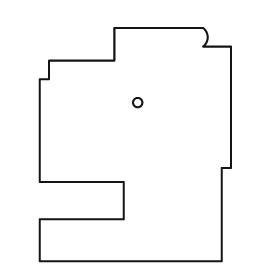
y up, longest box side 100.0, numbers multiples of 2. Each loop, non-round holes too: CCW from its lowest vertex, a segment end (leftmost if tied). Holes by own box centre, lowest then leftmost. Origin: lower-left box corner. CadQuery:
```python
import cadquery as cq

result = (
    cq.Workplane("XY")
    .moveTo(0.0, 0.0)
    .lineTo(78.0, 0.0)
    .lineTo(78.0, 40.0)
    .lineTo(82.0, 40.0)
    .lineTo(82.0, 92.0)
    .lineTo(70.0, 92.0)
    .threePointArc((72.0, 96.0), (70.0, 100.0))
    .lineTo(32.0, 100.0)
    .lineTo(32.0, 86.0)
    .lineTo(4.0, 86.0)
    .lineTo(4.0, 78.0)
    .lineTo(0.0, 78.0)
    .lineTo(0.0, 34.0)
    .lineTo(36.0, 34.0)
    .lineTo(36.0, 18.0)
    .lineTo(0.0, 18.0)
    .close()
    .moveTo(42.0, 68.0)
    .circle(2.0)
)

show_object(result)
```